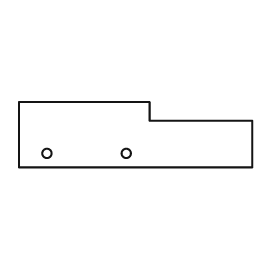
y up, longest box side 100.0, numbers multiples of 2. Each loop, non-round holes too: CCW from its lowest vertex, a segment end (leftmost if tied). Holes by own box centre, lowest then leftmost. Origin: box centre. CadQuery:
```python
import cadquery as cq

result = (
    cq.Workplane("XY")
    .moveTo(-50.0, -14.0)
    .lineTo(50.0, -14.0)
    .lineTo(50.0, 6.0)
    .lineTo(6.0, 6.0)
    .lineTo(6.0, 14.0)
    .lineTo(-50.0, 14.0)
    .close()
    .moveTo(-38.0, -8.0)
    .circle(2.0)
    .moveTo(-4.0, -8.0)
    .circle(2.0)
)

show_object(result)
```